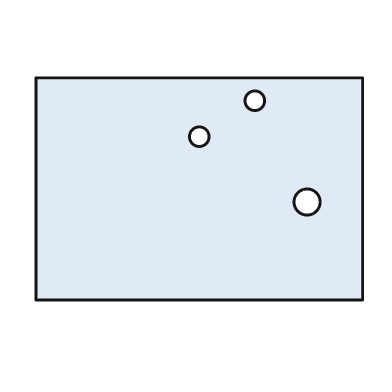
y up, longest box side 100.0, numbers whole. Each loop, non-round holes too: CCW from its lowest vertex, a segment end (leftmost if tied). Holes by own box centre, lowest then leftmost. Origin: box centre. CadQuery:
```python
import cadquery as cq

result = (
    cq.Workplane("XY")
    .moveTo(-50.0, -34.0)
    .lineTo(50.0, -34.0)
    .lineTo(50.0, 34.0)
    .lineTo(-50.0, 34.0)
    .close()
    .moveTo(33.0, -4.0)
    .circle(4.0)
    .moveTo(0.0, 16.0)
    .circle(3.0)
    .moveTo(17.0, 27.0)
    .circle(3.0)
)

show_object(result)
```